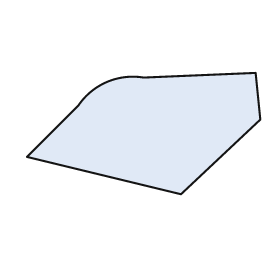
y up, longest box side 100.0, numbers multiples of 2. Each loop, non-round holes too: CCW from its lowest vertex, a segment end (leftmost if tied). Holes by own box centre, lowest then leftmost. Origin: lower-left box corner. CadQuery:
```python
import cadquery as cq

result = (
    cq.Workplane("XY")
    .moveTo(66.0, 0.0)
    .lineTo(100.0, 32.0)
    .lineTo(98.0, 52.0)
    .lineTo(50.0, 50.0)
    .threePointArc((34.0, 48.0), (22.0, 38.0))
    .lineTo(0.0, 16.0)
    .close()
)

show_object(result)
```